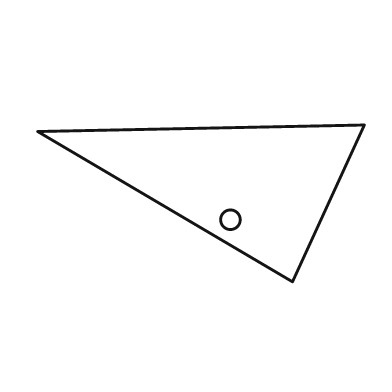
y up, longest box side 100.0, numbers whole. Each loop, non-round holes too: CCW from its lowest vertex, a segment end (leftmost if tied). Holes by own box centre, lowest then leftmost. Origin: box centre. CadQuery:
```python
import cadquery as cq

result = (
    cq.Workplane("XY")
    .moveTo(28.0, -24.0)
    .lineTo(50.0, 24.0)
    .lineTo(-50.0, 22.0)
    .close()
    .moveTo(9.0, -5.0)
    .circle(3.0)
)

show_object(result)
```